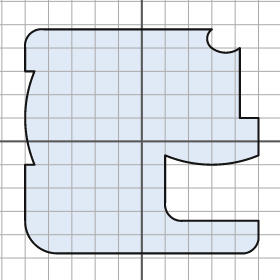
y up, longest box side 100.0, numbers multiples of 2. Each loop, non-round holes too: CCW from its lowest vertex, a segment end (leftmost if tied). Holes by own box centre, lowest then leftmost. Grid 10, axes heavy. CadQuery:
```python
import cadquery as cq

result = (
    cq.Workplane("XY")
    .moveTo(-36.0, -48.0)
    .lineTo(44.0, -48.0)
    .threePointArc((48.0, -46.0), (50.0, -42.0))
    .lineTo(50.0, -34.0)
    .lineTo(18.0, -34.0)
    .threePointArc((12.0, -32.0), (10.0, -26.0))
    .lineTo(10.0, -6.0)
    .threePointArc((30.0, -10.0), (50.0, -6.0))
    .lineTo(50.0, 10.0)
    .lineTo(42.0, 10.0)
    .lineTo(42.0, 40.0)
    .threePointArc((36.0, 38.0), (30.0, 40.0))
    .threePointArc((28.0, 44.0), (30.0, 48.0))
    .lineTo(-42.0, 48.0)
    .threePointArc((-48.0, 46.0), (-50.0, 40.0))
    .lineTo(-50.0, 30.0)
    .lineTo(-46.0, 30.0)
    .threePointArc((-50.0, 10.0), (-46.0, -10.0))
    .lineTo(-50.0, -10.0)
    .lineTo(-50.0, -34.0)
    .threePointArc((-46.0, -44.0), (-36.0, -48.0))
    .close()
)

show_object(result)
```